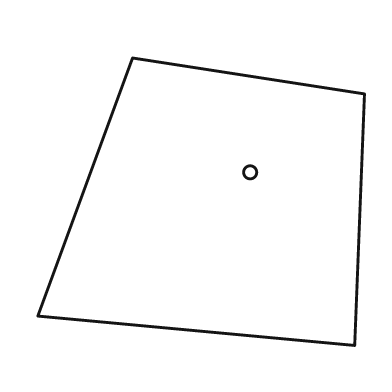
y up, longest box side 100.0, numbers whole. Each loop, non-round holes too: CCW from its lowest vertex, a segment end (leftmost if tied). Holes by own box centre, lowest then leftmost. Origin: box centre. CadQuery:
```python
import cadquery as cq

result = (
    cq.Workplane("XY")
    .moveTo(47.0, -44.0)
    .lineTo(50.0, 33.0)
    .lineTo(-21.0, 44.0)
    .lineTo(-50.0, -35.0)
    .close()
    .moveTo(15.0, 9.0)
    .circle(2.0)
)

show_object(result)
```